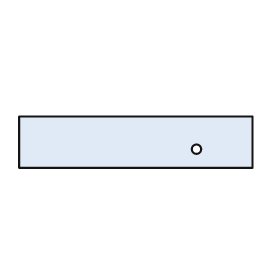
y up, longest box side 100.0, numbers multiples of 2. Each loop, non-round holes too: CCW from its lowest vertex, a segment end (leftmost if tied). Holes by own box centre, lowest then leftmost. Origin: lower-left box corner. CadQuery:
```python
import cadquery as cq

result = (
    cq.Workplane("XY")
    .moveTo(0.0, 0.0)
    .lineTo(100.0, 0.0)
    .lineTo(100.0, 22.0)
    .lineTo(0.0, 22.0)
    .close()
    .moveTo(76.0, 8.0)
    .circle(2.0)
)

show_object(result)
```